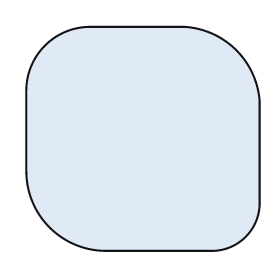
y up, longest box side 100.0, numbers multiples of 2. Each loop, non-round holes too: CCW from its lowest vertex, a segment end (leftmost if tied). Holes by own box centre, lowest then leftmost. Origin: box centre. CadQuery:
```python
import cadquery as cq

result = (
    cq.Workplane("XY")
    .moveTo(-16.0, -48.0)
    .lineTo(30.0, -48.0)
    .threePointArc((44.0, -42.0), (50.0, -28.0))
    .lineTo(50.0, 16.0)
    .threePointArc((40.0, 38.0), (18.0, 48.0))
    .lineTo(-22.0, 48.0)
    .threePointArc((-42.0, 40.0), (-50.0, 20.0))
    .lineTo(-50.0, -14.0)
    .threePointArc((-40.0, -38.0), (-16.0, -48.0))
    .close()
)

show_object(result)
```